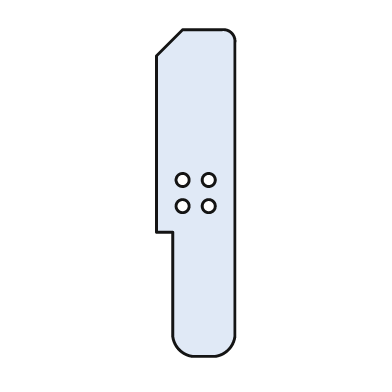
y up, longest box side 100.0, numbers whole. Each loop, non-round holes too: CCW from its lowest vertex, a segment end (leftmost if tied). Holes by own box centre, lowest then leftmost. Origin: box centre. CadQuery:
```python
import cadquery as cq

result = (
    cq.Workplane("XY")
    .moveTo(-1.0, -50.0)
    .lineTo(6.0, -50.0)
    .threePointArc((10.0, -48.0), (12.0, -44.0))
    .lineTo(12.0, 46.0)
    .threePointArc((11.0, 49.0), (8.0, 50.0))
    .lineTo(-4.0, 50.0)
    .lineTo(-12.0, 42.0)
    .lineTo(-12.0, -12.0)
    .lineTo(-7.0, -12.0)
    .lineTo(-7.0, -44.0)
    .threePointArc((-5.0, -48.0), (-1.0, -50.0))
    .close()
    .moveTo(-4.0, -4.0)
    .circle(2.0)
    .moveTo(4.0, -4.0)
    .circle(2.0)
    .moveTo(-4.0, 4.0)
    .circle(2.0)
    .moveTo(4.0, 4.0)
    .circle(2.0)
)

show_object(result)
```